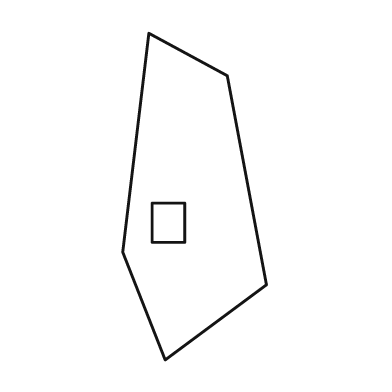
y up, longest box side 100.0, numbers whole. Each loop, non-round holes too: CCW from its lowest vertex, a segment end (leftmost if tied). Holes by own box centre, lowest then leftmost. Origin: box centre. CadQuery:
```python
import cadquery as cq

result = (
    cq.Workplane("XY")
    .moveTo(-9.0, -50.0)
    .lineTo(22.0, -27.0)
    .lineTo(10.0, 37.0)
    .lineTo(-14.0, 50.0)
    .lineTo(-22.0, -17.0)
    .close()
    .moveTo(-13.0, -14.0)
    .lineTo(-3.0, -14.0)
    .lineTo(-3.0, -2.0)
    .lineTo(-13.0, -2.0)
    .close()
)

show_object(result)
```